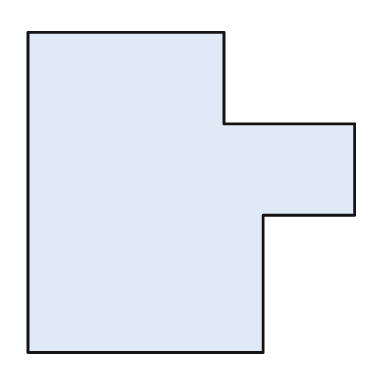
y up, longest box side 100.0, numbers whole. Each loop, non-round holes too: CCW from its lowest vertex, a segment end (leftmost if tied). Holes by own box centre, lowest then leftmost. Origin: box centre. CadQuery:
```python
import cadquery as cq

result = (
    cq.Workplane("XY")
    .moveTo(-50.0, -49.0)
    .lineTo(22.0, -49.0)
    .lineTo(22.0, -7.0)
    .lineTo(50.0, -7.0)
    .lineTo(50.0, 21.0)
    .lineTo(10.0, 21.0)
    .lineTo(10.0, 49.0)
    .lineTo(-50.0, 49.0)
    .close()
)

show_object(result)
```